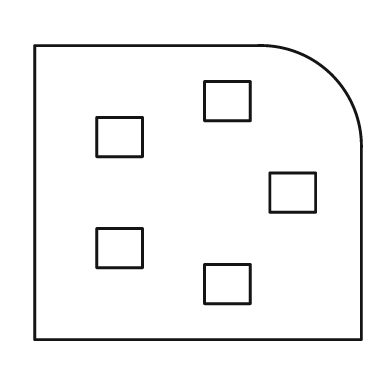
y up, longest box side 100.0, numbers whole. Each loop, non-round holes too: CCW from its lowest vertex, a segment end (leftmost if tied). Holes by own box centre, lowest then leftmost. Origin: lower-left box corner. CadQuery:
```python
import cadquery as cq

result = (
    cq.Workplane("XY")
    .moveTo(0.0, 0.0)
    .lineTo(100.0, 0.0)
    .lineTo(100.0, 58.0)
    .threePointArc((91.0, 81.0), (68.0, 90.0))
    .lineTo(0.0, 90.0)
    .close()
    .moveTo(52.0, 11.0)
    .lineTo(66.0, 11.0)
    .lineTo(66.0, 23.0)
    .lineTo(52.0, 23.0)
    .close()
    .moveTo(19.0, 22.0)
    .lineTo(33.0, 22.0)
    .lineTo(33.0, 34.0)
    .lineTo(19.0, 34.0)
    .close()
    .moveTo(72.0, 39.0)
    .lineTo(86.0, 39.0)
    .lineTo(86.0, 51.0)
    .lineTo(72.0, 51.0)
    .close()
    .moveTo(19.0, 56.0)
    .lineTo(33.0, 56.0)
    .lineTo(33.0, 68.0)
    .lineTo(19.0, 68.0)
    .close()
    .moveTo(52.0, 67.0)
    .lineTo(66.0, 67.0)
    .lineTo(66.0, 79.0)
    .lineTo(52.0, 79.0)
    .close()
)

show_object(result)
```